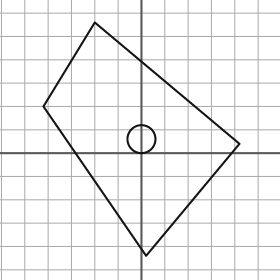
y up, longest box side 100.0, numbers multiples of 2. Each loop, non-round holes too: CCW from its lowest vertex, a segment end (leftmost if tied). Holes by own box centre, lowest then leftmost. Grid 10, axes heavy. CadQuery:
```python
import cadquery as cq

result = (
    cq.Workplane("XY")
    .moveTo(2.0, -44.0)
    .lineTo(42.0, 4.0)
    .lineTo(-20.0, 56.0)
    .lineTo(-42.0, 20.0)
    .close()
    .moveTo(0.0, 6.0)
    .circle(6.0)
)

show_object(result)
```